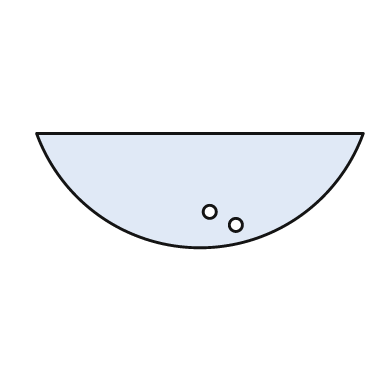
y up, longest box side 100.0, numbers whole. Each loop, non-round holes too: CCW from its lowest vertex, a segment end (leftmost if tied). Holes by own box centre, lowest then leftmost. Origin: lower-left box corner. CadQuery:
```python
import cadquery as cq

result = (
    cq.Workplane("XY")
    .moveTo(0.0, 35.0)
    .threePointArc((50.0, 0.0), (100.0, 35.0))
    .close()
    .moveTo(61.0, 7.0)
    .circle(2.0)
    .moveTo(53.0, 11.0)
    .circle(2.0)
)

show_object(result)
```